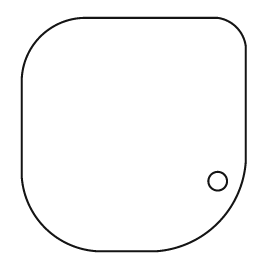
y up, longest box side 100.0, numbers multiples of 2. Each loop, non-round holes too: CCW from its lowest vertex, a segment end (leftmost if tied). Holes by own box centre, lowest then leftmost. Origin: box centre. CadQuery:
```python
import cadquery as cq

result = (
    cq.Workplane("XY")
    .moveTo(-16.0, -50.0)
    .lineTo(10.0, -50.0)
    .threePointArc((36.0, -38.0), (48.0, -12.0))
    .lineTo(48.0, 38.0)
    .threePointArc((44.0, 46.0), (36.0, 50.0))
    .lineTo(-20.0, 50.0)
    .threePointArc((-40.0, 42.0), (-48.0, 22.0))
    .lineTo(-48.0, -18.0)
    .threePointArc((-38.0, -40.0), (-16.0, -50.0))
    .close()
    .moveTo(36.0, -20.0)
    .circle(4.0)
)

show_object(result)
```